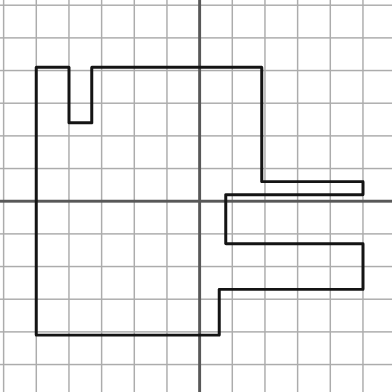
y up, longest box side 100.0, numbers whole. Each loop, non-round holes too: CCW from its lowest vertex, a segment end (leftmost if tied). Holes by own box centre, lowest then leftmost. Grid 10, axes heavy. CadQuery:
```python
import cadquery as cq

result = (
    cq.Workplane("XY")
    .moveTo(-50.0, -41.0)
    .lineTo(6.0, -41.0)
    .lineTo(6.0, -27.0)
    .lineTo(50.0, -27.0)
    .lineTo(50.0, -13.0)
    .lineTo(8.0, -13.0)
    .lineTo(8.0, 2.0)
    .lineTo(50.0, 2.0)
    .lineTo(50.0, 6.0)
    .lineTo(19.0, 6.0)
    .lineTo(19.0, 41.0)
    .lineTo(-33.0, 41.0)
    .lineTo(-33.0, 24.0)
    .lineTo(-40.0, 24.0)
    .lineTo(-40.0, 41.0)
    .lineTo(-50.0, 41.0)
    .close()
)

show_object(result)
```